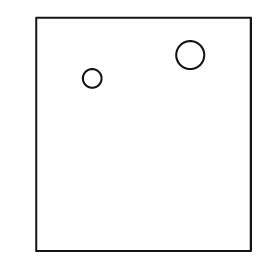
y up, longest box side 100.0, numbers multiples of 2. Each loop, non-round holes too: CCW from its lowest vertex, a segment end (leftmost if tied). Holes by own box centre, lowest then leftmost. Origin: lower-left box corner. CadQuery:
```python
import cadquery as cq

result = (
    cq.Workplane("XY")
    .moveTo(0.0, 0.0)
    .lineTo(92.0, 0.0)
    .lineTo(92.0, 100.0)
    .lineTo(0.0, 100.0)
    .close()
    .moveTo(24.0, 74.0)
    .circle(4.0)
    .moveTo(66.0, 84.0)
    .circle(6.0)
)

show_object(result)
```